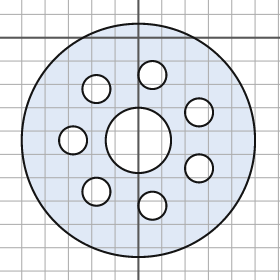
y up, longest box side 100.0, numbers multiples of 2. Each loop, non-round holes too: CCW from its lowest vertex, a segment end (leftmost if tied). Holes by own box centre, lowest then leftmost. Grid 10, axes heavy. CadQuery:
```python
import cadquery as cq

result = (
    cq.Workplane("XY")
    .moveTo(0.0, -44.0)
    .circle(50.0)
    .moveTo(6.0, -72.0)
    .circle(6.0)
    .moveTo(-18.0, -66.0)
    .circle(6.0)
    .moveTo(26.0, -56.0)
    .circle(6.0)
    .moveTo(-28.0, -44.0)
    .circle(6.0)
    .moveTo(0.0, -44.0)
    .circle(14.0)
    .moveTo(26.0, -32.0)
    .circle(6.0)
    .moveTo(-18.0, -22.0)
    .circle(6.0)
    .moveTo(6.0, -16.0)
    .circle(6.0)
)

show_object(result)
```